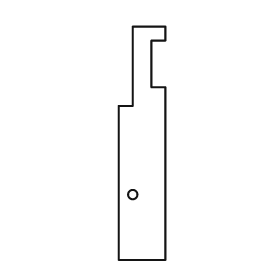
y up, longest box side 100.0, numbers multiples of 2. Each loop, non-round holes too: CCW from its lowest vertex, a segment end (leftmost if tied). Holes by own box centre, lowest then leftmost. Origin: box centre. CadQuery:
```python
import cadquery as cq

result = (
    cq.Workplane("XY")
    .moveTo(-10.0, -50.0)
    .lineTo(10.0, -50.0)
    .lineTo(10.0, 24.0)
    .lineTo(4.0, 24.0)
    .lineTo(4.0, 44.0)
    .lineTo(10.0, 44.0)
    .lineTo(10.0, 50.0)
    .lineTo(-4.0, 50.0)
    .lineTo(-4.0, 16.0)
    .lineTo(-10.0, 16.0)
    .close()
    .moveTo(-4.0, -22.0)
    .circle(2.0)
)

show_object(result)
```